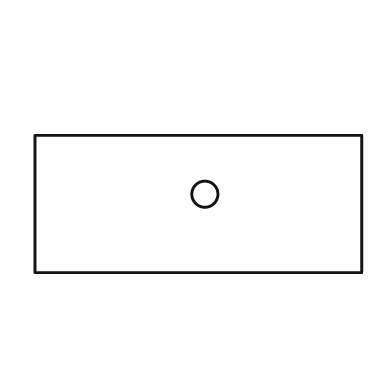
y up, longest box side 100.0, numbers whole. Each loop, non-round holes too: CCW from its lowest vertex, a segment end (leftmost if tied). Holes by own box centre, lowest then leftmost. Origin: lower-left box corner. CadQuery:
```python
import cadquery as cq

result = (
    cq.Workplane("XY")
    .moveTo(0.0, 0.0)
    .lineTo(100.0, 0.0)
    .lineTo(100.0, 42.0)
    .lineTo(0.0, 42.0)
    .close()
    .moveTo(52.0, 24.0)
    .circle(4.0)
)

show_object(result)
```